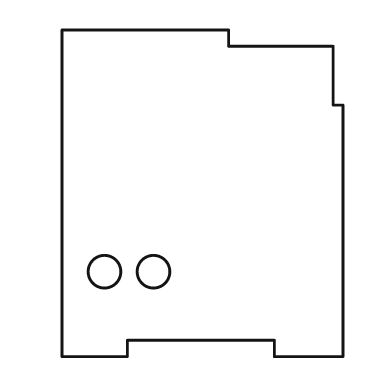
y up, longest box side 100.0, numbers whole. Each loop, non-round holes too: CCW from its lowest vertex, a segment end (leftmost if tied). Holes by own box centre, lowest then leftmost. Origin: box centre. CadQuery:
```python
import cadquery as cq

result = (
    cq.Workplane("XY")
    .moveTo(-43.0, -50.0)
    .lineTo(-23.0, -50.0)
    .lineTo(-23.0, -45.0)
    .lineTo(22.0, -45.0)
    .lineTo(22.0, -50.0)
    .lineTo(43.0, -50.0)
    .lineTo(43.0, 27.0)
    .lineTo(40.0, 27.0)
    .lineTo(40.0, 45.0)
    .lineTo(8.0, 45.0)
    .lineTo(8.0, 50.0)
    .lineTo(-43.0, 50.0)
    .close()
    .moveTo(-30.0, -24.0)
    .circle(5.0)
    .moveTo(-15.0, -24.0)
    .circle(5.0)
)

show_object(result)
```